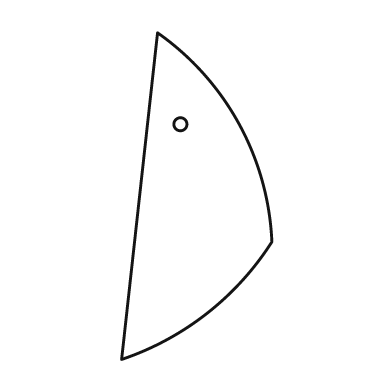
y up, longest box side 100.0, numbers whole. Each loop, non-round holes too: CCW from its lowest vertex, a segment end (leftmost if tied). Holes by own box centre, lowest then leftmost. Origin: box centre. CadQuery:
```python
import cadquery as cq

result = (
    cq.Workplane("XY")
    .moveTo(-23.0, -50.0)
    .threePointArc((3.0, -36.0), (23.0, -14.0))
    .threePointArc((13.0, 22.0), (-12.0, 50.0))
    .close()
    .moveTo(-5.0, 22.0)
    .circle(2.0)
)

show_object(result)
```